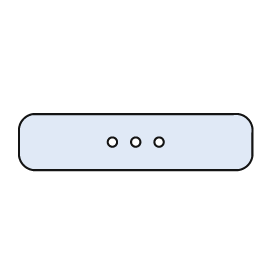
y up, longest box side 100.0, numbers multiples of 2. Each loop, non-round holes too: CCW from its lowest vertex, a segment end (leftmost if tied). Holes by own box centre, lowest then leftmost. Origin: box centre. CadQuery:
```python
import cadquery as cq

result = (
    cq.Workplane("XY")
    .moveTo(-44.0, -12.0)
    .lineTo(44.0, -12.0)
    .threePointArc((48.0, -10.0), (50.0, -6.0))
    .lineTo(50.0, 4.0)
    .threePointArc((48.0, 10.0), (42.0, 12.0))
    .lineTo(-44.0, 12.0)
    .threePointArc((-48.0, 10.0), (-50.0, 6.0))
    .lineTo(-50.0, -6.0)
    .threePointArc((-48.0, -10.0), (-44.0, -12.0))
    .close()
    .moveTo(-10.0, 0.0)
    .circle(2.0)
    .moveTo(0.0, 0.0)
    .circle(2.0)
    .moveTo(10.0, 0.0)
    .circle(2.0)
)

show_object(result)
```